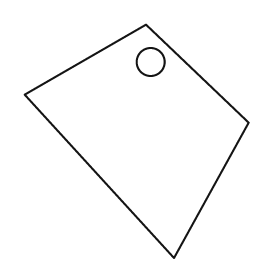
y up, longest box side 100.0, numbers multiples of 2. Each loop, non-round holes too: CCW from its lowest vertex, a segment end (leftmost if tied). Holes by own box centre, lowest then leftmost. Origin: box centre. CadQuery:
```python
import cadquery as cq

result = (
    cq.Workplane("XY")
    .moveTo(16.0, -50.0)
    .lineTo(48.0, 8.0)
    .lineTo(4.0, 50.0)
    .lineTo(-48.0, 20.0)
    .close()
    .moveTo(6.0, 34.0)
    .circle(6.0)
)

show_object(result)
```